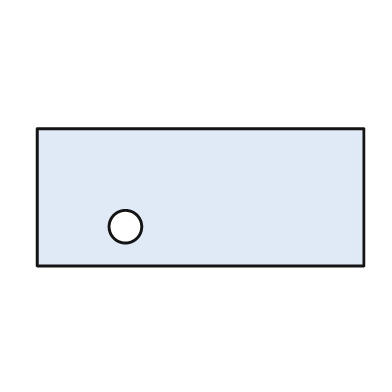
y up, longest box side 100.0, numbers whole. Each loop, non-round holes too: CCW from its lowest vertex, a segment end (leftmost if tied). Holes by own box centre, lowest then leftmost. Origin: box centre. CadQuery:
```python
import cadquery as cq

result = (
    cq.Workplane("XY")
    .moveTo(-50.0, -21.0)
    .lineTo(50.0, -21.0)
    .lineTo(50.0, 21.0)
    .lineTo(-50.0, 21.0)
    .close()
    .moveTo(-23.0, -9.0)
    .circle(5.0)
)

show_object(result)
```